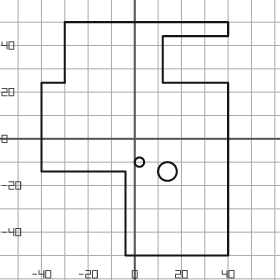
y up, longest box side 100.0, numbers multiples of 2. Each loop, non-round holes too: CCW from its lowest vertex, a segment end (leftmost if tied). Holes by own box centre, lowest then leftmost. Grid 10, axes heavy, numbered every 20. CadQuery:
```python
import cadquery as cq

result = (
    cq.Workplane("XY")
    .moveTo(-4.0, -50.0)
    .lineTo(40.0, -50.0)
    .lineTo(40.0, 24.0)
    .lineTo(12.0, 24.0)
    .lineTo(12.0, 44.0)
    .lineTo(40.0, 44.0)
    .lineTo(40.0, 50.0)
    .lineTo(-30.0, 50.0)
    .lineTo(-30.0, 24.0)
    .lineTo(-40.0, 24.0)
    .lineTo(-40.0, -14.0)
    .lineTo(-4.0, -14.0)
    .close()
    .moveTo(14.0, -14.0)
    .circle(4.0)
    .moveTo(2.0, -10.0)
    .circle(2.0)
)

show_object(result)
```